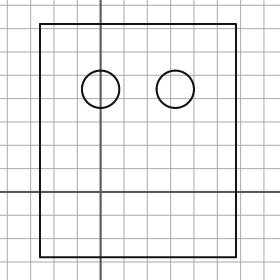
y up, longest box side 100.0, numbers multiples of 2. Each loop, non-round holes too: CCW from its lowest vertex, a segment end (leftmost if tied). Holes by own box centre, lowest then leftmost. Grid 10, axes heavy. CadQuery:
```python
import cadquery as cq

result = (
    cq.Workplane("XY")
    .moveTo(-26.0, -28.0)
    .lineTo(58.0, -28.0)
    .lineTo(58.0, 72.0)
    .lineTo(-26.0, 72.0)
    .close()
    .moveTo(0.0, 44.0)
    .circle(8.0)
    .moveTo(32.0, 44.0)
    .circle(8.0)
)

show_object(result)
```